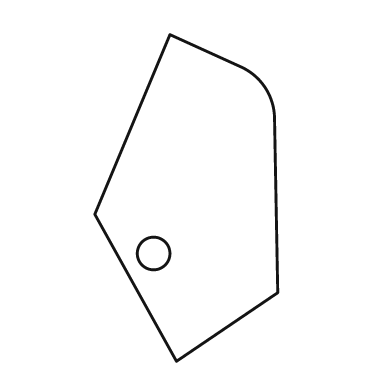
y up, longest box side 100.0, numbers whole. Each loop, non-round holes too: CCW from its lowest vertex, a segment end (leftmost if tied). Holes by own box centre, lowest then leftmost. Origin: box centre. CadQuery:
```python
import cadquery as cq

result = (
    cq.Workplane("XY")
    .moveTo(-3.0, -50.0)
    .lineTo(28.0, -29.0)
    .lineTo(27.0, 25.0)
    .threePointArc((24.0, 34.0), (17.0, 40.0))
    .lineTo(-5.0, 50.0)
    .lineTo(-28.0, -5.0)
    .close()
    .moveTo(-10.0, -17.0)
    .circle(5.0)
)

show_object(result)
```